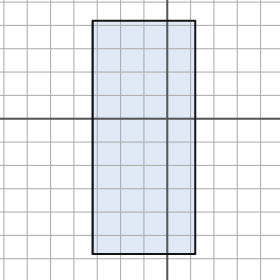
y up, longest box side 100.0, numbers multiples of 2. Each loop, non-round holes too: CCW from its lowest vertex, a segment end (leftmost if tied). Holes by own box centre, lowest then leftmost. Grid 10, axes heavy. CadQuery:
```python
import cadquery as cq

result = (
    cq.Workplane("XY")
    .moveTo(-32.0, -58.0)
    .lineTo(12.0, -58.0)
    .lineTo(12.0, 42.0)
    .lineTo(-32.0, 42.0)
    .close()
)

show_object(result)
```